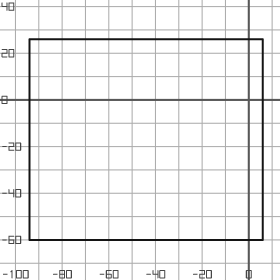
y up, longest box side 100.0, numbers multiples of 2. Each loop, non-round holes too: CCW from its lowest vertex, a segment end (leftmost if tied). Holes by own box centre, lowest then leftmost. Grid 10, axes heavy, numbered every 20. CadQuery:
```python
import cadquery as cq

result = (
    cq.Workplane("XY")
    .moveTo(-94.0, -60.0)
    .lineTo(6.0, -60.0)
    .lineTo(6.0, 26.0)
    .lineTo(-94.0, 26.0)
    .close()
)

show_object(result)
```